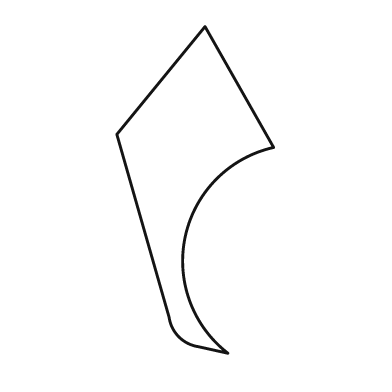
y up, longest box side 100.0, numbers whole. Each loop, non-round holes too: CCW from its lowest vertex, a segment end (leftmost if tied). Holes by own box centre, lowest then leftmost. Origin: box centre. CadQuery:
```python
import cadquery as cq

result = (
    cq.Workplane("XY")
    .moveTo(10.0, -50.0)
    .threePointArc((-3.0, -14.0), (24.0, 13.0))
    .lineTo(3.0, 50.0)
    .lineTo(-24.0, 17.0)
    .lineTo(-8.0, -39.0)
    .threePointArc((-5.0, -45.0), (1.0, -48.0))
    .close()
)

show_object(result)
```